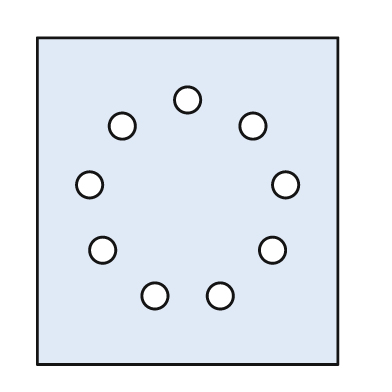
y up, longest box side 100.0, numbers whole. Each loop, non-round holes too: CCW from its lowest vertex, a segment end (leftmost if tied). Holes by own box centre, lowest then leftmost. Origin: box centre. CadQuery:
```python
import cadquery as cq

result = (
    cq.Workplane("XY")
    .moveTo(-46.0, -50.0)
    .lineTo(46.0, -50.0)
    .lineTo(46.0, 50.0)
    .lineTo(-46.0, 50.0)
    .close()
    .moveTo(-10.0, -29.0)
    .circle(4.0)
    .moveTo(10.0, -29.0)
    .circle(4.0)
    .moveTo(-26.0, -15.0)
    .circle(4.0)
    .moveTo(26.0, -15.0)
    .circle(4.0)
    .moveTo(-30.0, 5.0)
    .circle(4.0)
    .moveTo(30.0, 5.0)
    .circle(4.0)
    .moveTo(-20.0, 23.0)
    .circle(4.0)
    .moveTo(20.0, 23.0)
    .circle(4.0)
    .moveTo(0.0, 31.0)
    .circle(4.0)
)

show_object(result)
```